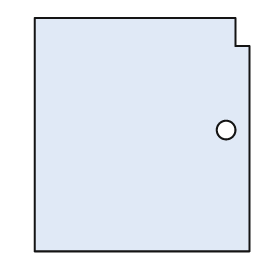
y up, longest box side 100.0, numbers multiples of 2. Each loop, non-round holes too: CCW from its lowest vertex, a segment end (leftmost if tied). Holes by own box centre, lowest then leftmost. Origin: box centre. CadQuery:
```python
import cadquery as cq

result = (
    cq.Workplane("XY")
    .moveTo(-46.0, -50.0)
    .lineTo(46.0, -50.0)
    .lineTo(46.0, 38.0)
    .lineTo(40.0, 38.0)
    .lineTo(40.0, 50.0)
    .lineTo(-46.0, 50.0)
    .close()
    .moveTo(36.0, 2.0)
    .circle(4.0)
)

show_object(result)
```